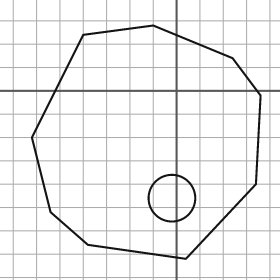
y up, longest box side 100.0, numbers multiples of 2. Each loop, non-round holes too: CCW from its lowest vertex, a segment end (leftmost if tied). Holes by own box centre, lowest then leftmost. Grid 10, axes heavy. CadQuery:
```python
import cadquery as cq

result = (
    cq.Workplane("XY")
    .moveTo(4.0, -72.0)
    .lineTo(34.0, -40.0)
    .lineTo(36.0, -2.0)
    .lineTo(24.0, 14.0)
    .lineTo(-10.0, 28.0)
    .lineTo(-40.0, 24.0)
    .lineTo(-62.0, -20.0)
    .lineTo(-54.0, -52.0)
    .lineTo(-38.0, -66.0)
    .close()
    .moveTo(-2.0, -46.0)
    .circle(10.0)
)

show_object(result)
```